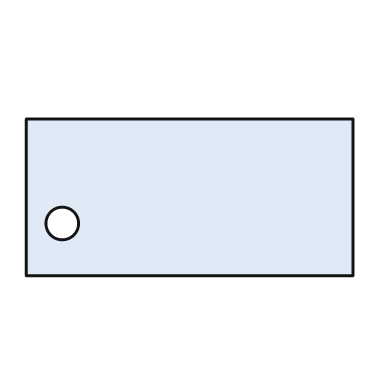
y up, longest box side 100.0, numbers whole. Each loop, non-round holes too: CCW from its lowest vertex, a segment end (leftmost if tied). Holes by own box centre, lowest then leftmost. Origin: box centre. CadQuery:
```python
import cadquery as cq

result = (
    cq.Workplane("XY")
    .moveTo(-50.0, -24.0)
    .lineTo(50.0, -24.0)
    .lineTo(50.0, 24.0)
    .lineTo(-50.0, 24.0)
    .close()
    .moveTo(-39.0, -8.0)
    .circle(5.0)
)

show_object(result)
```